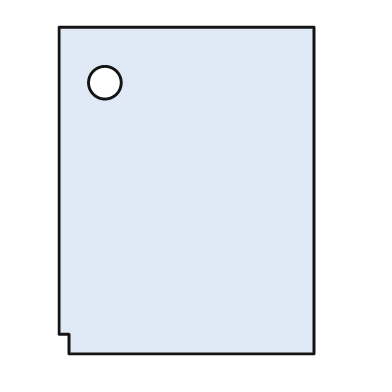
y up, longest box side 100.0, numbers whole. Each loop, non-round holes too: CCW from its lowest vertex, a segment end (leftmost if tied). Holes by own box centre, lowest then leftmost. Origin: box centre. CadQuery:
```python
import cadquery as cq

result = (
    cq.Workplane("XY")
    .moveTo(-36.0, -50.0)
    .lineTo(39.0, -50.0)
    .lineTo(39.0, 50.0)
    .lineTo(-39.0, 50.0)
    .lineTo(-39.0, -44.0)
    .lineTo(-36.0, -44.0)
    .close()
    .moveTo(-25.0, 33.0)
    .circle(5.0)
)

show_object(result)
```